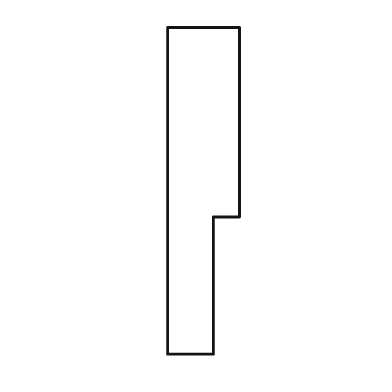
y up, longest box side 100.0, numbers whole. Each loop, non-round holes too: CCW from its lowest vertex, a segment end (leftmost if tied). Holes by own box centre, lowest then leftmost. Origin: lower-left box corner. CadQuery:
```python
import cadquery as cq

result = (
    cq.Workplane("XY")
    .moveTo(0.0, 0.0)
    .lineTo(14.0, 0.0)
    .lineTo(14.0, 42.0)
    .lineTo(22.0, 42.0)
    .lineTo(22.0, 100.0)
    .lineTo(0.0, 100.0)
    .close()
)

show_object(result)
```